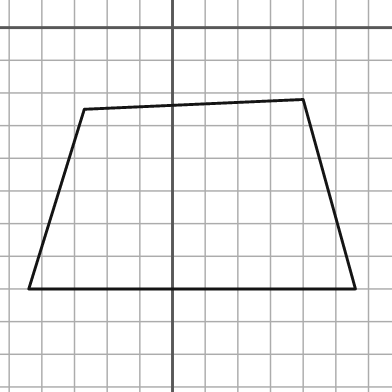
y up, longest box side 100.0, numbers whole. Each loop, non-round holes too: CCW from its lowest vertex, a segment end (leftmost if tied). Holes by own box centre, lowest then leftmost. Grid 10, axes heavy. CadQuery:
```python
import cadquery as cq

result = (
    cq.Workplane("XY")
    .moveTo(-44.0, -80.0)
    .lineTo(56.0, -80.0)
    .lineTo(40.0, -22.0)
    .lineTo(-27.0, -25.0)
    .close()
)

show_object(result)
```